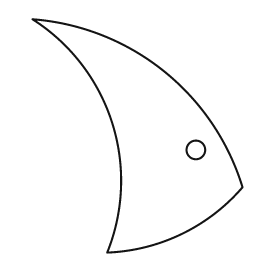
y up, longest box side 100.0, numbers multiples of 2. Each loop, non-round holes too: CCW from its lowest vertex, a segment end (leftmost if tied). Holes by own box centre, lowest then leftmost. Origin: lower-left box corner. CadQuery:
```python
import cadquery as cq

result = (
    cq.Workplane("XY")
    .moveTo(32.0, 0.0)
    .threePointArc((64.0, 8.0), (90.0, 28.0))
    .threePointArc((56.0, 78.0), (0.0, 100.0))
    .threePointArc((34.0, 56.0), (32.0, 0.0))
    .close()
    .moveTo(70.0, 44.0)
    .circle(4.0)
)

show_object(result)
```